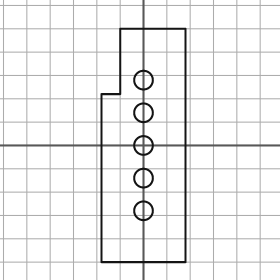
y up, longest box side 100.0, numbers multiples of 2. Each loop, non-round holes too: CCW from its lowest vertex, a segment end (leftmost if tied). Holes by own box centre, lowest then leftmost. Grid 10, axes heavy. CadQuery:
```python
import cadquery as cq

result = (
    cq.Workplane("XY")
    .moveTo(-18.0, -50.0)
    .lineTo(18.0, -50.0)
    .lineTo(18.0, 50.0)
    .lineTo(-10.0, 50.0)
    .lineTo(-10.0, 22.0)
    .lineTo(-18.0, 22.0)
    .close()
    .moveTo(0.0, -28.0)
    .circle(4.0)
    .moveTo(0.0, -14.0)
    .circle(4.0)
    .moveTo(0.0, 0.0)
    .circle(4.0)
    .moveTo(0.0, 14.0)
    .circle(4.0)
    .moveTo(0.0, 28.0)
    .circle(4.0)
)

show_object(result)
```